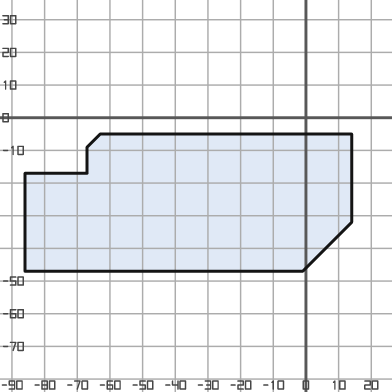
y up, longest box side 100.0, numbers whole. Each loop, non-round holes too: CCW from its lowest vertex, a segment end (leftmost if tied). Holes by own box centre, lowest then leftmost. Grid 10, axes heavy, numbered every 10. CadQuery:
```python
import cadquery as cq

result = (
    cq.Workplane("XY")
    .moveTo(-86.0, -47.0)
    .lineTo(-1.0, -47.0)
    .lineTo(14.0, -32.0)
    .lineTo(14.0, -5.0)
    .lineTo(-63.0, -5.0)
    .lineTo(-67.0, -9.0)
    .lineTo(-67.0, -17.0)
    .lineTo(-86.0, -17.0)
    .close()
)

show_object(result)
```